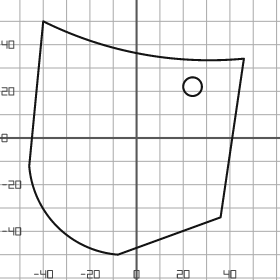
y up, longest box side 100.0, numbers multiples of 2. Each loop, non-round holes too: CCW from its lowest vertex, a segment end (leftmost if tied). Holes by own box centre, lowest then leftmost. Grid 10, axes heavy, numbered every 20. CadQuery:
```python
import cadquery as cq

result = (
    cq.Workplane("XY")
    .moveTo(-8.0, -50.0)
    .lineTo(36.0, -34.0)
    .lineTo(46.0, 34.0)
    .threePointArc((2.0, 36.0), (-40.0, 50.0))
    .lineTo(-46.0, -12.0)
    .threePointArc((-34.0, -38.0), (-8.0, -50.0))
    .close()
    .moveTo(24.0, 22.0)
    .circle(4.0)
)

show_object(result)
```